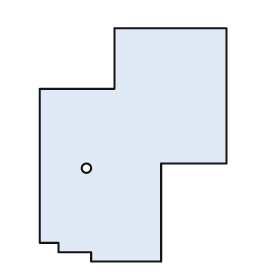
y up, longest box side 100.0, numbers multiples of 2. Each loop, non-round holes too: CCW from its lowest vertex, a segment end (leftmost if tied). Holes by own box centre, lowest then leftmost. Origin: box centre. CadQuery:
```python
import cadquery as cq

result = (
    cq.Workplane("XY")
    .moveTo(-18.0, -50.0)
    .lineTo(12.0, -50.0)
    .lineTo(12.0, -8.0)
    .lineTo(40.0, -8.0)
    .lineTo(40.0, 50.0)
    .lineTo(-8.0, 50.0)
    .lineTo(-8.0, 24.0)
    .lineTo(-40.0, 24.0)
    .lineTo(-40.0, -42.0)
    .lineTo(-32.0, -42.0)
    .lineTo(-32.0, -46.0)
    .lineTo(-18.0, -46.0)
    .close()
    .moveTo(-20.0, -10.0)
    .circle(2.0)
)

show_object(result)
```